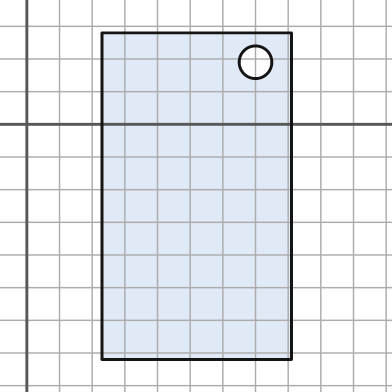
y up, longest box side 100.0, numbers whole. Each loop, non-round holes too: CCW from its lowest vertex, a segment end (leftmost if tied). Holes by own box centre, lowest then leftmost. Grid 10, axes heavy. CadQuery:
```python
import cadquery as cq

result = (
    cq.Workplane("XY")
    .moveTo(23.0, -72.0)
    .lineTo(81.0, -72.0)
    .lineTo(81.0, 28.0)
    .lineTo(23.0, 28.0)
    .close()
    .moveTo(70.0, 19.0)
    .circle(5.0)
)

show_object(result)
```